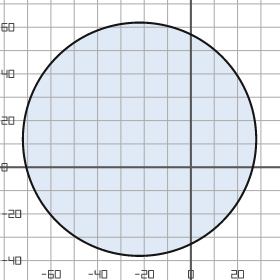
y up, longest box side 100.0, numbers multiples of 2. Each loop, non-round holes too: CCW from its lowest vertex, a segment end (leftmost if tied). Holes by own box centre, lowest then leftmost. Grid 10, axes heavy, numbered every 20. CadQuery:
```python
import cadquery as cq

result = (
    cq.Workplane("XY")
    .moveTo(-22.0, 12.0)
    .circle(50.0)
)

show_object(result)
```